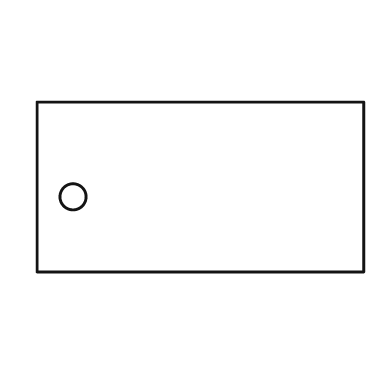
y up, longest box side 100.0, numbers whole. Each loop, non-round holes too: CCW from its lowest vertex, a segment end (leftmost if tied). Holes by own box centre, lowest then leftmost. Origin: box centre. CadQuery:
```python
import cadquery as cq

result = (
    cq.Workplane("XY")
    .moveTo(-50.0, -26.0)
    .lineTo(50.0, -26.0)
    .lineTo(50.0, 26.0)
    .lineTo(-50.0, 26.0)
    .close()
    .moveTo(-39.0, -3.0)
    .circle(4.0)
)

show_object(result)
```